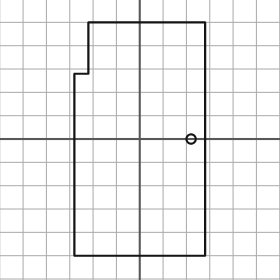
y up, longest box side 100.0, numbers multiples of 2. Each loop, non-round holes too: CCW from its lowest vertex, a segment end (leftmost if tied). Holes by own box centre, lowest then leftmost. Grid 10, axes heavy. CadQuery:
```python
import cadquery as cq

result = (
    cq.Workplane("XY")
    .moveTo(-28.0, -50.0)
    .lineTo(28.0, -50.0)
    .lineTo(28.0, 50.0)
    .lineTo(-22.0, 50.0)
    .lineTo(-22.0, 28.0)
    .lineTo(-28.0, 28.0)
    .close()
    .moveTo(22.0, 0.0)
    .circle(2.0)
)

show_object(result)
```